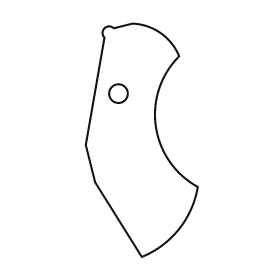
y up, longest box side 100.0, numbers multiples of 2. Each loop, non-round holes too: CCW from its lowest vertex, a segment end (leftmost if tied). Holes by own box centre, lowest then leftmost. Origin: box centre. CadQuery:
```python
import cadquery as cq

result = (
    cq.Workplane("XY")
    .moveTo(0.0, -50.0)
    .threePointArc((16.0, -38.0), (24.0, -20.0))
    .threePointArc((6.0, 6.0), (16.0, 36.0))
    .threePointArc((8.0, 46.0), (-4.0, 50.0))
    .lineTo(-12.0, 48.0)
    .threePointArc((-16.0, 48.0), (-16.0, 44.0))
    .lineTo(-24.0, -2.0)
    .lineTo(-20.0, -18.0)
    .close()
    .moveTo(-10.0, 20.0)
    .circle(4.0)
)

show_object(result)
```